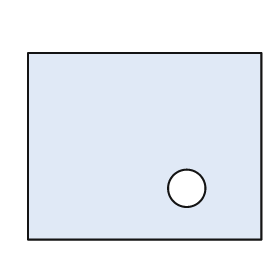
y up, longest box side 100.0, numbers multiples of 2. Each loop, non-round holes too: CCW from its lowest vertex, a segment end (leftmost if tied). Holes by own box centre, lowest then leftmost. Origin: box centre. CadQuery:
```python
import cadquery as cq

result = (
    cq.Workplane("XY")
    .moveTo(-50.0, -40.0)
    .lineTo(50.0, -40.0)
    .lineTo(50.0, 40.0)
    .lineTo(-50.0, 40.0)
    .close()
    .moveTo(18.0, -18.0)
    .circle(8.0)
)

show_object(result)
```